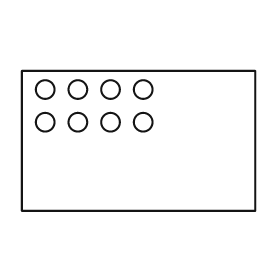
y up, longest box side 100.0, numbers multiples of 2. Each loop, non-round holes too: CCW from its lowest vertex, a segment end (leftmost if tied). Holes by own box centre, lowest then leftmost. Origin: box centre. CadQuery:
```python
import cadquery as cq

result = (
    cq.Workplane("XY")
    .moveTo(-50.0, -30.0)
    .lineTo(50.0, -30.0)
    .lineTo(50.0, 30.0)
    .lineTo(-50.0, 30.0)
    .close()
    .moveTo(-40.0, 8.0)
    .circle(4.0)
    .moveTo(-26.0, 8.0)
    .circle(4.0)
    .moveTo(-12.0, 8.0)
    .circle(4.0)
    .moveTo(2.0, 8.0)
    .circle(4.0)
    .moveTo(-40.0, 22.0)
    .circle(4.0)
    .moveTo(-26.0, 22.0)
    .circle(4.0)
    .moveTo(-12.0, 22.0)
    .circle(4.0)
    .moveTo(2.0, 22.0)
    .circle(4.0)
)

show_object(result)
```